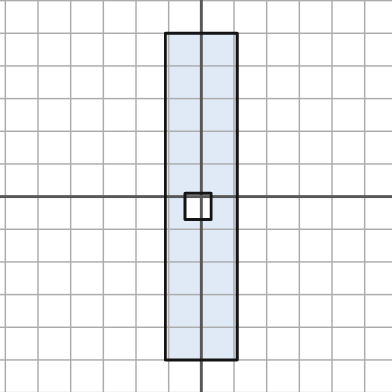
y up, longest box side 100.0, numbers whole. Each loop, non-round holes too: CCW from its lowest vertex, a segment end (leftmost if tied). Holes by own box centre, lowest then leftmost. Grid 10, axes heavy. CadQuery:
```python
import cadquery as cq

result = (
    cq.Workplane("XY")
    .moveTo(-11.0, -50.0)
    .lineTo(11.0, -50.0)
    .lineTo(11.0, 50.0)
    .lineTo(-11.0, 50.0)
    .close()
    .moveTo(-5.0, -7.0)
    .lineTo(3.0, -7.0)
    .lineTo(3.0, 1.0)
    .lineTo(-5.0, 1.0)
    .close()
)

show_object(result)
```